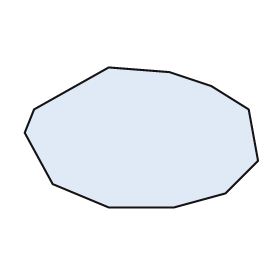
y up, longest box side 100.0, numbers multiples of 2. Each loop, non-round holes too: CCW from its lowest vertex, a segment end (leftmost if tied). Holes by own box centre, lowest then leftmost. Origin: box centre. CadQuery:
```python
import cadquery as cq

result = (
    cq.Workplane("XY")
    .moveTo(-14.0, -30.0)
    .lineTo(14.0, -30.0)
    .lineTo(36.0, -24.0)
    .lineTo(50.0, -10.0)
    .lineTo(46.0, 12.0)
    .lineTo(30.0, 22.0)
    .lineTo(12.0, 28.0)
    .lineTo(-14.0, 30.0)
    .lineTo(-46.0, 12.0)
    .lineTo(-50.0, 2.0)
    .lineTo(-38.0, -20.0)
    .close()
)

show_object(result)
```